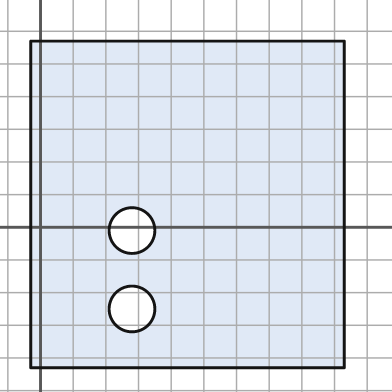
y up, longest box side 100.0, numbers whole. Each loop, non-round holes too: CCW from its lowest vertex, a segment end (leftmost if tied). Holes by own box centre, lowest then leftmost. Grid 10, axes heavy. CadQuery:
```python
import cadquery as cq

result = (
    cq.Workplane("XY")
    .moveTo(-3.0, -43.0)
    .lineTo(93.0, -43.0)
    .lineTo(93.0, 57.0)
    .lineTo(-3.0, 57.0)
    .close()
    .moveTo(28.0, -25.0)
    .circle(7.0)
    .moveTo(28.0, -1.0)
    .circle(7.0)
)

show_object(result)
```